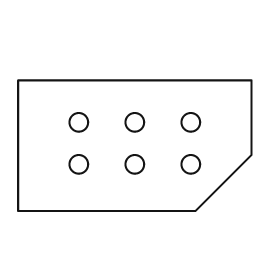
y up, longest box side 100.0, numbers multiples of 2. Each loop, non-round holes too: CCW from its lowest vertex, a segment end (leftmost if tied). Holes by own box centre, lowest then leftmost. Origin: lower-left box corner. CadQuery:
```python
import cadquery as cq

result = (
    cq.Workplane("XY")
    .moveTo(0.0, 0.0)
    .lineTo(76.0, 0.0)
    .lineTo(100.0, 24.0)
    .lineTo(100.0, 56.0)
    .lineTo(0.0, 56.0)
    .close()
    .moveTo(26.0, 20.0)
    .circle(4.0)
    .moveTo(50.0, 20.0)
    .circle(4.0)
    .moveTo(74.0, 20.0)
    .circle(4.0)
    .moveTo(26.0, 38.0)
    .circle(4.0)
    .moveTo(50.0, 38.0)
    .circle(4.0)
    .moveTo(74.0, 38.0)
    .circle(4.0)
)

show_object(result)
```